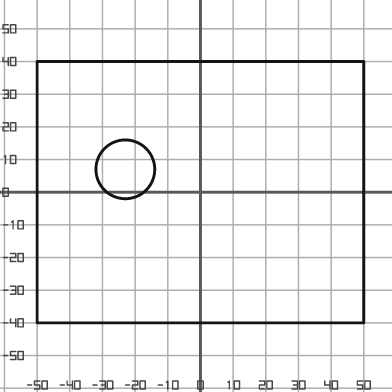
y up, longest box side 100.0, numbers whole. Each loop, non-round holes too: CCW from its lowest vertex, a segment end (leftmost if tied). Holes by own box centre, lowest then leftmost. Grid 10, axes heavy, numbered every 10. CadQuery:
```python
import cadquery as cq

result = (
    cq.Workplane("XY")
    .moveTo(-50.0, -40.0)
    .lineTo(50.0, -40.0)
    .lineTo(50.0, 40.0)
    .lineTo(-50.0, 40.0)
    .close()
    .moveTo(-23.0, 7.0)
    .circle(9.0)
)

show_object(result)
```